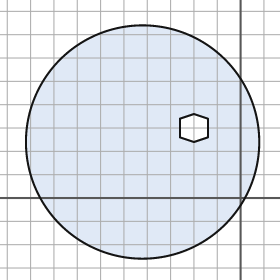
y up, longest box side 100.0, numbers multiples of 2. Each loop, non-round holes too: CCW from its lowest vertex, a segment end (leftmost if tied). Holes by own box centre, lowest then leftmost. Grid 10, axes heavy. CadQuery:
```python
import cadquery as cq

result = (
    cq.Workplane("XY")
    .moveTo(-42.0, 24.0)
    .circle(50.0)
    .moveTo(-20.0, 24.0)
    .lineTo(-14.0, 26.0)
    .lineTo(-14.0, 34.0)
    .lineTo(-20.0, 36.0)
    .lineTo(-26.0, 34.0)
    .lineTo(-26.0, 26.0)
    .close()
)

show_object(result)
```